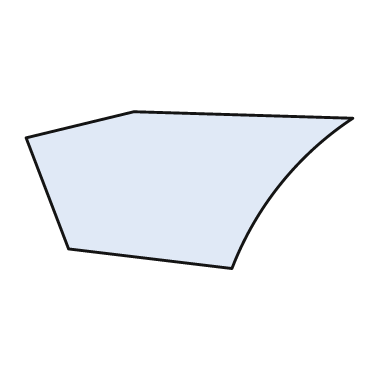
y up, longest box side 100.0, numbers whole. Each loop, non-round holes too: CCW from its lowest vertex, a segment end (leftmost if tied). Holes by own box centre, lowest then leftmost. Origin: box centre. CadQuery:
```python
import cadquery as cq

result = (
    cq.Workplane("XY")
    .moveTo(13.0, -24.0)
    .threePointArc((28.0, 2.0), (50.0, 22.0))
    .lineTo(-17.0, 24.0)
    .lineTo(-50.0, 16.0)
    .lineTo(-37.0, -18.0)
    .close()
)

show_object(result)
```